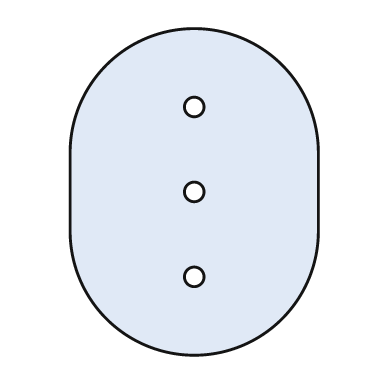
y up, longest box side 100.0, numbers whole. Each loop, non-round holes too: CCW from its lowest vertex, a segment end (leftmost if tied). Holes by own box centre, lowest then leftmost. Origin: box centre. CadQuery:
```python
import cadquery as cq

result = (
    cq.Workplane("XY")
    .moveTo(-38.0, -12.0)
    .threePointArc((0.0, -50.0), (38.0, -12.0))
    .lineTo(38.0, 12.0)
    .threePointArc((0.0, 50.0), (-38.0, 12.0))
    .close()
    .moveTo(0.0, -26.0)
    .circle(3.0)
    .moveTo(0.0, 0.0)
    .circle(3.0)
    .moveTo(0.0, 26.0)
    .circle(3.0)
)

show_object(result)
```